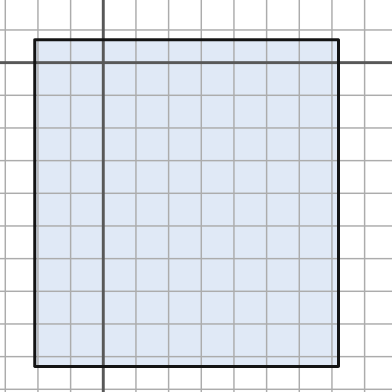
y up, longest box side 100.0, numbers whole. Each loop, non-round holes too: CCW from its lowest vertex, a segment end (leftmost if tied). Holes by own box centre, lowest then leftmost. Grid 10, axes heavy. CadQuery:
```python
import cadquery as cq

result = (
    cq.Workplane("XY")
    .moveTo(-21.0, -93.0)
    .lineTo(72.0, -93.0)
    .lineTo(72.0, 7.0)
    .lineTo(-21.0, 7.0)
    .close()
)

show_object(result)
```